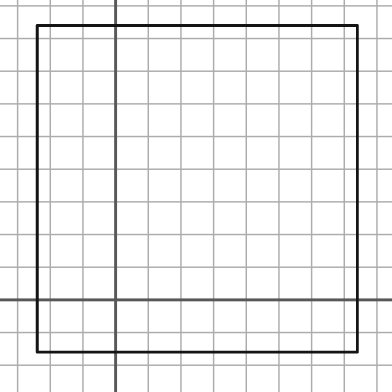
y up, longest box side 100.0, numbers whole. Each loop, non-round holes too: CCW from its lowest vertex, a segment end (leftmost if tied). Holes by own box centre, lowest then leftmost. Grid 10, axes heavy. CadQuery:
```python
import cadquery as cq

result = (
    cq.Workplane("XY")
    .moveTo(-24.0, -16.0)
    .lineTo(74.0, -16.0)
    .lineTo(74.0, 84.0)
    .lineTo(-24.0, 84.0)
    .close()
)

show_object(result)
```